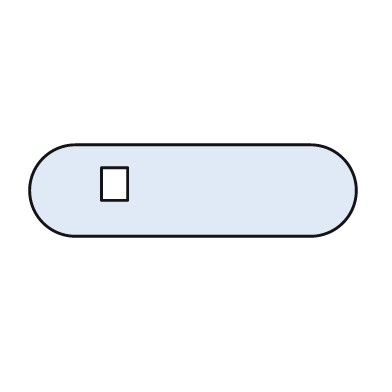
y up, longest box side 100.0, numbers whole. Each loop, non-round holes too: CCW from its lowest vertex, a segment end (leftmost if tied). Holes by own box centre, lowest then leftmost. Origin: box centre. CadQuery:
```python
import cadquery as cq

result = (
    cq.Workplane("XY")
    .moveTo(-36.0, -14.0)
    .lineTo(36.0, -14.0)
    .threePointArc((50.0, 0.0), (36.0, 14.0))
    .lineTo(-36.0, 14.0)
    .threePointArc((-50.0, 0.0), (-36.0, -14.0))
    .close()
    .moveTo(-28.0, -3.0)
    .lineTo(-20.0, -3.0)
    .lineTo(-20.0, 7.0)
    .lineTo(-28.0, 7.0)
    .close()
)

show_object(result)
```